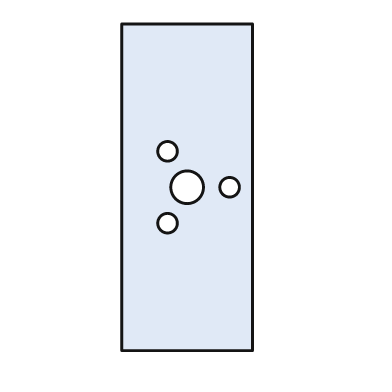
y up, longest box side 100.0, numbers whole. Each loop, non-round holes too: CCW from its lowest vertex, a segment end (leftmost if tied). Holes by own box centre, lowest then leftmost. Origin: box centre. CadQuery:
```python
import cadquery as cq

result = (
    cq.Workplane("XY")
    .moveTo(-20.0, -50.0)
    .lineTo(20.0, -50.0)
    .lineTo(20.0, 50.0)
    .lineTo(-20.0, 50.0)
    .close()
    .moveTo(-6.0, -11.0)
    .circle(3.0)
    .moveTo(0.0, 0.0)
    .circle(5.0)
    .moveTo(13.0, 0.0)
    .circle(3.0)
    .moveTo(-6.0, 11.0)
    .circle(3.0)
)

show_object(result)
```